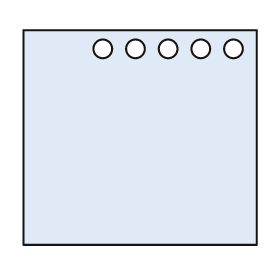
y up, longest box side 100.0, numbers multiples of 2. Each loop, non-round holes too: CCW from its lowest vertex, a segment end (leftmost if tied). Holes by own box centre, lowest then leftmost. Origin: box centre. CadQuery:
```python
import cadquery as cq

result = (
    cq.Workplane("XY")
    .moveTo(-50.0, -46.0)
    .lineTo(50.0, -46.0)
    .lineTo(50.0, 46.0)
    .lineTo(-50.0, 46.0)
    .close()
    .moveTo(-16.0, 38.0)
    .circle(4.0)
    .moveTo(-2.0, 38.0)
    .circle(4.0)
    .moveTo(12.0, 38.0)
    .circle(4.0)
    .moveTo(26.0, 38.0)
    .circle(4.0)
    .moveTo(40.0, 38.0)
    .circle(4.0)
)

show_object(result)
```